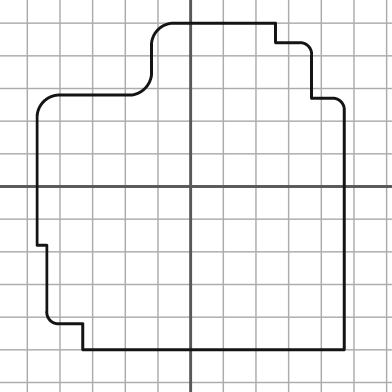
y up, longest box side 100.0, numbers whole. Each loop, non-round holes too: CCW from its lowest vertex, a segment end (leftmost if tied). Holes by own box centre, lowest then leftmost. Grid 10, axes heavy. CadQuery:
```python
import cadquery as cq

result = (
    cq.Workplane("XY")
    .moveTo(-33.0, -50.0)
    .lineTo(47.0, -50.0)
    .lineTo(47.0, 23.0)
    .threePointArc((46.0, 26.0), (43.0, 27.0))
    .lineTo(37.0, 27.0)
    .lineTo(37.0, 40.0)
    .threePointArc((36.0, 43.0), (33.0, 44.0))
    .lineTo(26.0, 44.0)
    .lineTo(26.0, 50.0)
    .lineTo(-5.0, 50.0)
    .threePointArc((-10.0, 48.0), (-12.0, 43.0))
    .lineTo(-12.0, 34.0)
    .threePointArc((-14.0, 30.0), (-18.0, 28.0))
    .lineTo(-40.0, 28.0)
    .threePointArc((-45.0, 26.0), (-47.0, 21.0))
    .lineTo(-47.0, -18.0)
    .lineTo(-44.0, -18.0)
    .lineTo(-44.0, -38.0)
    .threePointArc((-43.0, -41.0), (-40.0, -42.0))
    .lineTo(-33.0, -42.0)
    .close()
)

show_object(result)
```